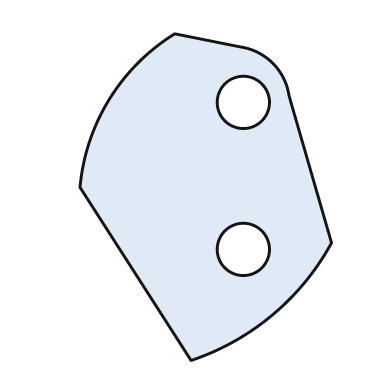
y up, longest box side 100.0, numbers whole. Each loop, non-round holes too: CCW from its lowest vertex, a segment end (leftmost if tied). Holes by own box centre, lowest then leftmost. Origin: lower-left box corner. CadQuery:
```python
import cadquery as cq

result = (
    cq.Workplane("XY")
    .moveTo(34.0, 0.0)
    .threePointArc((59.0, 14.0), (77.0, 36.0))
    .lineTo(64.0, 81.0)
    .threePointArc((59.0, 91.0), (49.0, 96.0))
    .lineTo(29.0, 100.0)
    .threePointArc((9.0, 80.0), (0.0, 53.0))
    .close()
    .moveTo(50.0, 34.0)
    .circle(8.0)
    .moveTo(50.0, 79.0)
    .circle(8.0)
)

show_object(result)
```